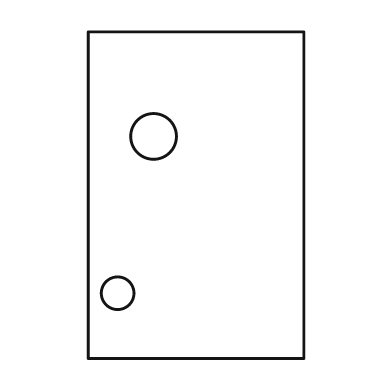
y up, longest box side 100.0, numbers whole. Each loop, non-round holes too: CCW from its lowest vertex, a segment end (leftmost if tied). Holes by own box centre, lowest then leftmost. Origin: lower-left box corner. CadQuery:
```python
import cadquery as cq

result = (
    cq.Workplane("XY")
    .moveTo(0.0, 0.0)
    .lineTo(66.0, 0.0)
    .lineTo(66.0, 100.0)
    .lineTo(0.0, 100.0)
    .close()
    .moveTo(9.0, 20.0)
    .circle(5.0)
    .moveTo(20.0, 68.0)
    .circle(7.0)
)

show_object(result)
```